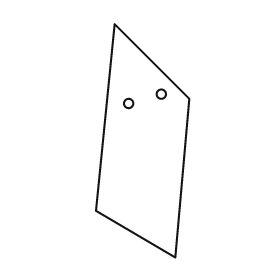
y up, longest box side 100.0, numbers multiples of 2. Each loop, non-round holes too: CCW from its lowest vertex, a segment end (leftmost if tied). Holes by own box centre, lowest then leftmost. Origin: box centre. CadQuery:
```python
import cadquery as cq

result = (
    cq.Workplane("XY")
    .moveTo(14.0, -50.0)
    .lineTo(20.0, 18.0)
    .lineTo(-12.0, 50.0)
    .lineTo(-20.0, -30.0)
    .close()
    .moveTo(-6.0, 16.0)
    .circle(2.0)
    .moveTo(8.0, 20.0)
    .circle(2.0)
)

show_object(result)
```